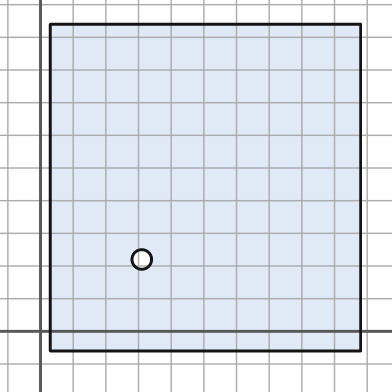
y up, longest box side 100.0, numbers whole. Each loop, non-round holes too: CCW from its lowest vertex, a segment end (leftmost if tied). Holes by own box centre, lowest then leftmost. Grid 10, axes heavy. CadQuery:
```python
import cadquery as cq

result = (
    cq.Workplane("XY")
    .moveTo(3.0, -6.0)
    .lineTo(98.0, -6.0)
    .lineTo(98.0, 94.0)
    .lineTo(3.0, 94.0)
    .close()
    .moveTo(31.0, 22.0)
    .circle(3.0)
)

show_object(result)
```